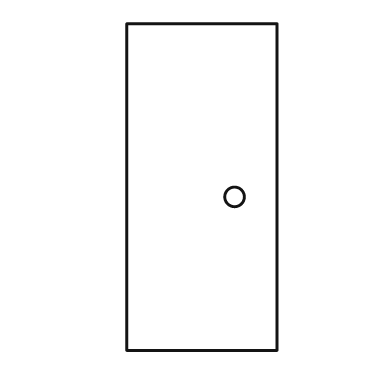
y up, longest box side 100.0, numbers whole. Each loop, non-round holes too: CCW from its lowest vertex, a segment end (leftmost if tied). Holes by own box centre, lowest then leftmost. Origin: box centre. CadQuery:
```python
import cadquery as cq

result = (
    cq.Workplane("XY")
    .moveTo(-23.0, -50.0)
    .lineTo(23.0, -50.0)
    .lineTo(23.0, 50.0)
    .lineTo(-23.0, 50.0)
    .close()
    .moveTo(10.0, -3.0)
    .circle(3.0)
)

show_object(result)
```